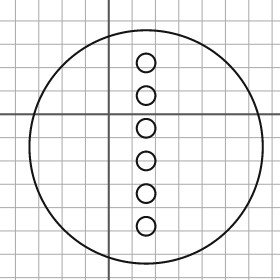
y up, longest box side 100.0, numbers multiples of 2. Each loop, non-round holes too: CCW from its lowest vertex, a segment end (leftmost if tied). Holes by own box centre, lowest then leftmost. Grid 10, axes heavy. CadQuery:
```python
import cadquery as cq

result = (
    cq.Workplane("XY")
    .moveTo(16.0, -14.0)
    .circle(50.0)
    .moveTo(16.0, -48.0)
    .circle(4.0)
    .moveTo(16.0, -34.0)
    .circle(4.0)
    .moveTo(16.0, -20.0)
    .circle(4.0)
    .moveTo(16.0, -6.0)
    .circle(4.0)
    .moveTo(16.0, 8.0)
    .circle(4.0)
    .moveTo(16.0, 22.0)
    .circle(4.0)
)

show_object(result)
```